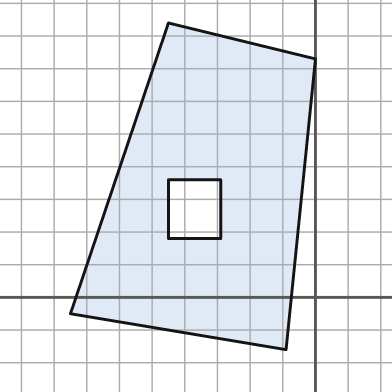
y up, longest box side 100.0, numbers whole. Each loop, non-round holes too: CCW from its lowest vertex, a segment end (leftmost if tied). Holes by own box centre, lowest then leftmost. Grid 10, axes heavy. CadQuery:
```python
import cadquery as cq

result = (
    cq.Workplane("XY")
    .moveTo(-9.0, -16.0)
    .lineTo(0.0, 73.0)
    .lineTo(-45.0, 84.0)
    .lineTo(-75.0, -5.0)
    .close()
    .moveTo(-45.0, 18.0)
    .lineTo(-29.0, 18.0)
    .lineTo(-29.0, 36.0)
    .lineTo(-45.0, 36.0)
    .close()
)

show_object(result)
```